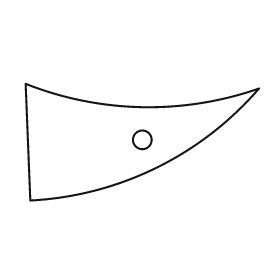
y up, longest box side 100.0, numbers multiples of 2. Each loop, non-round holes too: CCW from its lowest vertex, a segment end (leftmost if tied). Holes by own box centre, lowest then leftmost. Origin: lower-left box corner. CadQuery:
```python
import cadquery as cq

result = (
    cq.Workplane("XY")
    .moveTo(2.0, 0.0)
    .threePointArc((56.0, 14.0), (100.0, 48.0))
    .threePointArc((50.0, 40.0), (0.0, 50.0))
    .close()
    .moveTo(50.0, 26.0)
    .circle(4.0)
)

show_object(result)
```